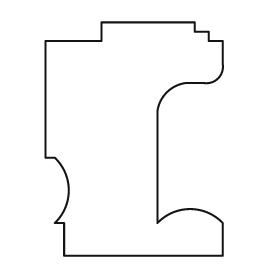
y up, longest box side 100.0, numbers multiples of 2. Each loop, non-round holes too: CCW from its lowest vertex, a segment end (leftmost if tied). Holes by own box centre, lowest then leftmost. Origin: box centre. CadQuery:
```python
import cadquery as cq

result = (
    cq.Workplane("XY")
    .moveTo(-30.0, -50.0)
    .lineTo(38.0, -50.0)
    .lineTo(38.0, -36.0)
    .threePointArc((24.0, -30.0), (10.0, -36.0))
    .lineTo(10.0, 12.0)
    .threePointArc((14.0, 20.0), (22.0, 24.0))
    .lineTo(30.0, 24.0)
    .threePointArc((36.0, 26.0), (38.0, 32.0))
    .lineTo(38.0, 42.0)
    .lineTo(32.0, 42.0)
    .lineTo(32.0, 46.0)
    .lineTo(26.0, 46.0)
    .lineTo(26.0, 50.0)
    .lineTo(-14.0, 50.0)
    .lineTo(-14.0, 42.0)
    .lineTo(-38.0, 42.0)
    .lineTo(-38.0, -8.0)
    .lineTo(-34.0, -8.0)
    .threePointArc((-28.0, -22.0), (-34.0, -36.0))
    .lineTo(-30.0, -36.0)
    .close()
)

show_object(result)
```